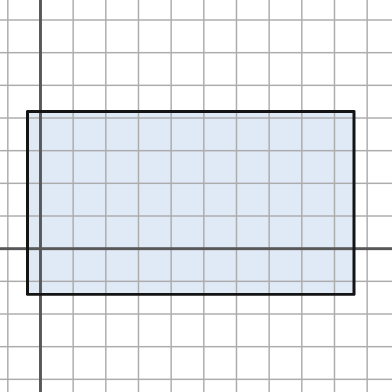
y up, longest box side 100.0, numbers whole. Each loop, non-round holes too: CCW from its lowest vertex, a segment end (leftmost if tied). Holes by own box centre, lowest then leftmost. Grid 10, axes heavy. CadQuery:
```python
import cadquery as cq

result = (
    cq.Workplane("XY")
    .moveTo(-4.0, -14.0)
    .lineTo(96.0, -14.0)
    .lineTo(96.0, 42.0)
    .lineTo(-4.0, 42.0)
    .close()
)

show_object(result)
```